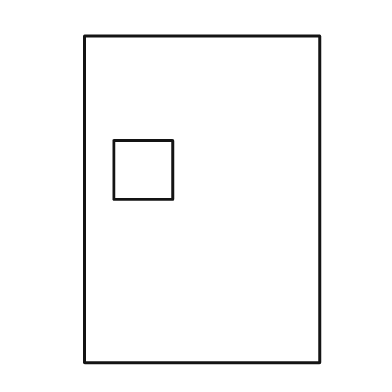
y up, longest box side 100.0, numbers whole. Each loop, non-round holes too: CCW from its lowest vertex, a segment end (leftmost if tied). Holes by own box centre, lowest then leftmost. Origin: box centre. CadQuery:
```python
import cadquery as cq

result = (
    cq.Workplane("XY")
    .moveTo(-36.0, -50.0)
    .lineTo(36.0, -50.0)
    .lineTo(36.0, 50.0)
    .lineTo(-36.0, 50.0)
    .close()
    .moveTo(-27.0, 0.0)
    .lineTo(-9.0, 0.0)
    .lineTo(-9.0, 18.0)
    .lineTo(-27.0, 18.0)
    .close()
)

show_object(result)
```